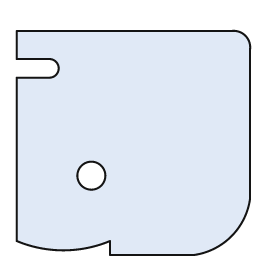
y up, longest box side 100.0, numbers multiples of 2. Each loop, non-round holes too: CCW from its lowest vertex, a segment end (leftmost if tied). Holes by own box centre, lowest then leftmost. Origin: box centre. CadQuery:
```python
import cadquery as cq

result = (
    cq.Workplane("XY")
    .moveTo(-10.0, -48.0)
    .lineTo(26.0, -48.0)
    .threePointArc((42.0, -40.0), (50.0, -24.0))
    .lineTo(50.0, 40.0)
    .threePointArc((48.0, 46.0), (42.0, 48.0))
    .lineTo(-50.0, 48.0)
    .lineTo(-50.0, 36.0)
    .lineTo(-36.0, 36.0)
    .threePointArc((-32.0, 32.0), (-36.0, 28.0))
    .lineTo(-50.0, 28.0)
    .lineTo(-50.0, -42.0)
    .threePointArc((-30.0, -46.0), (-10.0, -42.0))
    .close()
    .moveTo(-18.0, -14.0)
    .circle(6.0)
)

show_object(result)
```